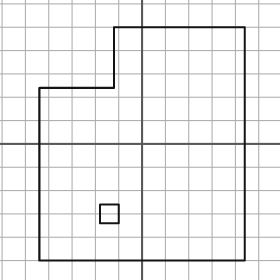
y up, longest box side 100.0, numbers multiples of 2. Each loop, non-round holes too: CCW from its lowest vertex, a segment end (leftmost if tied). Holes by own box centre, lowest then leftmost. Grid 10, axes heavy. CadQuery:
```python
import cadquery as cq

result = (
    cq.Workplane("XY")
    .moveTo(-44.0, -50.0)
    .lineTo(44.0, -50.0)
    .lineTo(44.0, 50.0)
    .lineTo(-12.0, 50.0)
    .lineTo(-12.0, 24.0)
    .lineTo(-44.0, 24.0)
    .close()
    .moveTo(-18.0, -34.0)
    .lineTo(-10.0, -34.0)
    .lineTo(-10.0, -26.0)
    .lineTo(-18.0, -26.0)
    .close()
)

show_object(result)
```